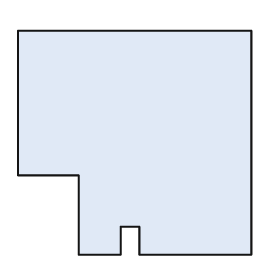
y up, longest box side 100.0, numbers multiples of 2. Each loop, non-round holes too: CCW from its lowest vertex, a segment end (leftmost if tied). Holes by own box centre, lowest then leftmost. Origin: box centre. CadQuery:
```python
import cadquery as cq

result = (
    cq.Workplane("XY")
    .moveTo(-24.0, -48.0)
    .lineTo(-6.0, -48.0)
    .lineTo(-6.0, -36.0)
    .lineTo(2.0, -36.0)
    .lineTo(2.0, -48.0)
    .lineTo(50.0, -48.0)
    .lineTo(50.0, 48.0)
    .lineTo(-50.0, 48.0)
    .lineTo(-50.0, -14.0)
    .lineTo(-24.0, -14.0)
    .close()
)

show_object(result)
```